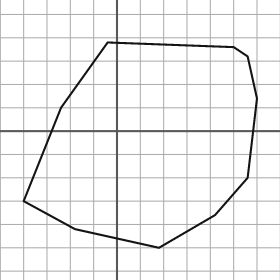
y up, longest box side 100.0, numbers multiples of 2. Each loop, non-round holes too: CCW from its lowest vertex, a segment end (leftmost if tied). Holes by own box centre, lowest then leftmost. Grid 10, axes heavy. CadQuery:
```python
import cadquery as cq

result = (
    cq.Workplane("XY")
    .moveTo(18.0, -50.0)
    .lineTo(42.0, -36.0)
    .lineTo(56.0, -20.0)
    .lineTo(60.0, 14.0)
    .lineTo(56.0, 32.0)
    .lineTo(50.0, 36.0)
    .lineTo(-4.0, 38.0)
    .lineTo(-24.0, 10.0)
    .lineTo(-40.0, -30.0)
    .lineTo(-18.0, -42.0)
    .close()
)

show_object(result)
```